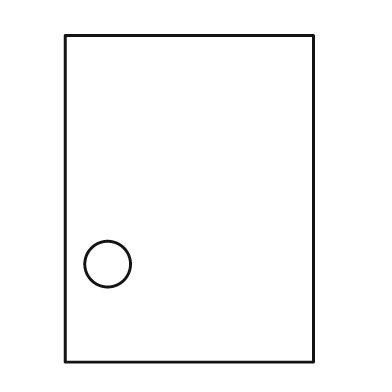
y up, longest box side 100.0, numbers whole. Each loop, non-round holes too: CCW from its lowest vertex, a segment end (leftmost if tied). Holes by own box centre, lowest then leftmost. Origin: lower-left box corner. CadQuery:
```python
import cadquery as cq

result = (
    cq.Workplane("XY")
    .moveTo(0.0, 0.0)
    .lineTo(76.0, 0.0)
    .lineTo(76.0, 100.0)
    .lineTo(0.0, 100.0)
    .close()
    .moveTo(13.0, 30.0)
    .circle(7.0)
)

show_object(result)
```